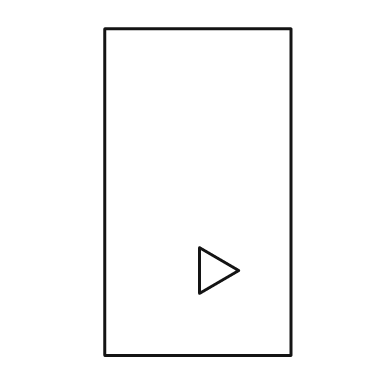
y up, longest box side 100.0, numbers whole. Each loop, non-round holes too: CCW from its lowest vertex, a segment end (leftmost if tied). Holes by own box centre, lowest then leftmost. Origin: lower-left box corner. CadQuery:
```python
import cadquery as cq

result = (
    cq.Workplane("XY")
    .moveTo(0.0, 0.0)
    .lineTo(57.0, 0.0)
    .lineTo(57.0, 100.0)
    .lineTo(0.0, 100.0)
    .close()
    .moveTo(29.0, 19.0)
    .lineTo(41.0, 26.0)
    .lineTo(29.0, 33.0)
    .close()
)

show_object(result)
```